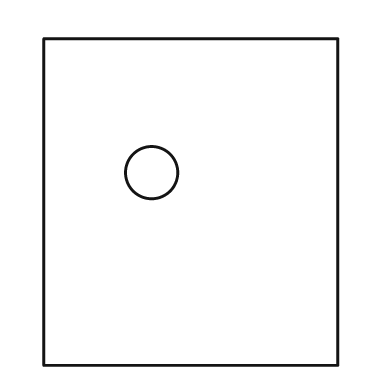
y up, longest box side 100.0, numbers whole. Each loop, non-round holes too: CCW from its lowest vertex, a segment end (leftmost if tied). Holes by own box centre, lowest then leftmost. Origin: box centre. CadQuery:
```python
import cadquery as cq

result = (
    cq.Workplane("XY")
    .moveTo(-45.0, -50.0)
    .lineTo(45.0, -50.0)
    .lineTo(45.0, 50.0)
    .lineTo(-45.0, 50.0)
    .close()
    .moveTo(-12.0, 9.0)
    .circle(8.0)
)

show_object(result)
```